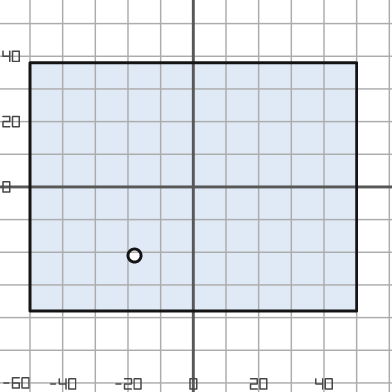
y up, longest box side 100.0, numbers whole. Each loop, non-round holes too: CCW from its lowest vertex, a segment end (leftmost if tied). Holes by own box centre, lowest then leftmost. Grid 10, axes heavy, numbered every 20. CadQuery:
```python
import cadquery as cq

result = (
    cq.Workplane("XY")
    .moveTo(-50.0, -38.0)
    .lineTo(50.0, -38.0)
    .lineTo(50.0, 38.0)
    .lineTo(-50.0, 38.0)
    .close()
    .moveTo(-18.0, -21.0)
    .circle(2.0)
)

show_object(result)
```